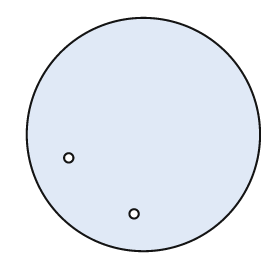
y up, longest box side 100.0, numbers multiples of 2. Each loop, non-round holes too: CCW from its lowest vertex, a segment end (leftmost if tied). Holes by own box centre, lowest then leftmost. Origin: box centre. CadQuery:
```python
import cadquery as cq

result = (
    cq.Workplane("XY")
    .moveTo(0.0, 0.0)
    .circle(50.0)
    .moveTo(-4.0, -34.0)
    .circle(2.0)
    .moveTo(-32.0, -10.0)
    .circle(2.0)
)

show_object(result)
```